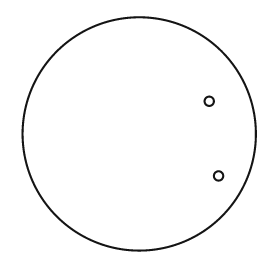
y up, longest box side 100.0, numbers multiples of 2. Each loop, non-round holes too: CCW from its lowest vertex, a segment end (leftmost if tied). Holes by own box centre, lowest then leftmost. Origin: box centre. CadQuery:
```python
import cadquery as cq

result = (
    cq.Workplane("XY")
    .moveTo(0.0, 0.0)
    .circle(50.0)
    .moveTo(34.0, -18.0)
    .circle(2.0)
    .moveTo(30.0, 14.0)
    .circle(2.0)
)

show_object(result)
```